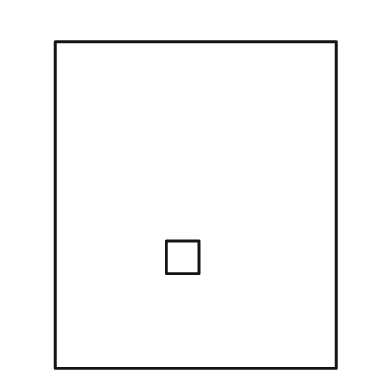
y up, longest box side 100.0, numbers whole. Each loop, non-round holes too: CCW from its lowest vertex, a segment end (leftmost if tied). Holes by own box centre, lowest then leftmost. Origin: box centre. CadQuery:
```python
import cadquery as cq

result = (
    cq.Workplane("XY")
    .moveTo(-43.0, -50.0)
    .lineTo(43.0, -50.0)
    .lineTo(43.0, 50.0)
    .lineTo(-43.0, 50.0)
    .close()
    .moveTo(-9.0, -21.0)
    .lineTo(1.0, -21.0)
    .lineTo(1.0, -11.0)
    .lineTo(-9.0, -11.0)
    .close()
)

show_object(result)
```